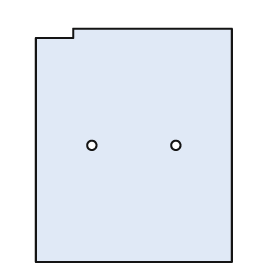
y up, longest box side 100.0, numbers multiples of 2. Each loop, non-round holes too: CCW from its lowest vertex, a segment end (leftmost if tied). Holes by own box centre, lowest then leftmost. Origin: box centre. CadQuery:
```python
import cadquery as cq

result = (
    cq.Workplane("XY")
    .moveTo(-42.0, -50.0)
    .lineTo(42.0, -50.0)
    .lineTo(42.0, 50.0)
    .lineTo(-26.0, 50.0)
    .lineTo(-26.0, 46.0)
    .lineTo(-42.0, 46.0)
    .close()
    .moveTo(-18.0, 0.0)
    .circle(2.0)
    .moveTo(18.0, 0.0)
    .circle(2.0)
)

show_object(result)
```